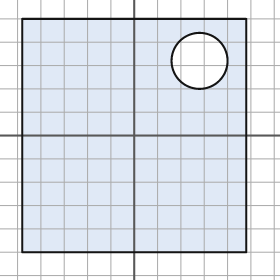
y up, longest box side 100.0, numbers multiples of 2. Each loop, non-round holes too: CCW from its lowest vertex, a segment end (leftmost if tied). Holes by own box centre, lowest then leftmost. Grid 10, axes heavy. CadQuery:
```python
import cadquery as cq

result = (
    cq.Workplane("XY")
    .moveTo(-48.0, -50.0)
    .lineTo(48.0, -50.0)
    .lineTo(48.0, 50.0)
    .lineTo(-48.0, 50.0)
    .close()
    .moveTo(28.0, 32.0)
    .circle(12.0)
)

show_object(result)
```